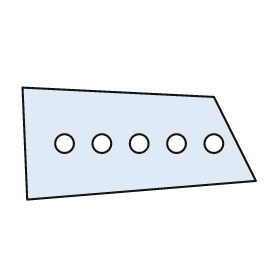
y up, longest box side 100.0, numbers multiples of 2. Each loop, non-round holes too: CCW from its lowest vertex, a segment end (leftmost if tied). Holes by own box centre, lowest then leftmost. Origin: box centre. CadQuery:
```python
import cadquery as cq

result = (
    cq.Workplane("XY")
    .moveTo(-48.0, -24.0)
    .lineTo(50.0, -16.0)
    .lineTo(32.0, 20.0)
    .lineTo(-50.0, 24.0)
    .close()
    .moveTo(-32.0, 0.0)
    .circle(4.0)
    .moveTo(-16.0, 0.0)
    .circle(4.0)
    .moveTo(0.0, 0.0)
    .circle(4.0)
    .moveTo(16.0, 0.0)
    .circle(4.0)
    .moveTo(32.0, 0.0)
    .circle(4.0)
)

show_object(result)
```